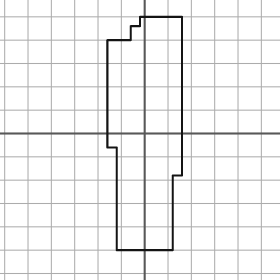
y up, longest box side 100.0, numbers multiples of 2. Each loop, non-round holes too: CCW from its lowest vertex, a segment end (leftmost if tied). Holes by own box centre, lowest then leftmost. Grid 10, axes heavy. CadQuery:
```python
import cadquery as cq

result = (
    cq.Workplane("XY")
    .moveTo(-12.0, -50.0)
    .lineTo(12.0, -50.0)
    .lineTo(12.0, -18.0)
    .lineTo(16.0, -18.0)
    .lineTo(16.0, 50.0)
    .lineTo(-2.0, 50.0)
    .lineTo(-2.0, 46.0)
    .lineTo(-6.0, 46.0)
    .lineTo(-6.0, 40.0)
    .lineTo(-16.0, 40.0)
    .lineTo(-16.0, -6.0)
    .lineTo(-12.0, -6.0)
    .close()
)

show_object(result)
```